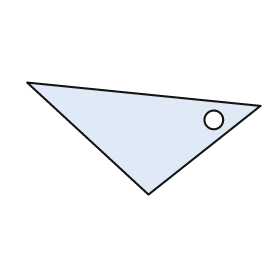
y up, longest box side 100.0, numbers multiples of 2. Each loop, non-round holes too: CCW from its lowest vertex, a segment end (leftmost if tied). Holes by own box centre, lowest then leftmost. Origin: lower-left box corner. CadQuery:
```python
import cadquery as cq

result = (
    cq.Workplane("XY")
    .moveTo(52.0, 0.0)
    .lineTo(100.0, 38.0)
    .lineTo(0.0, 48.0)
    .close()
    .moveTo(80.0, 32.0)
    .circle(4.0)
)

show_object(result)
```